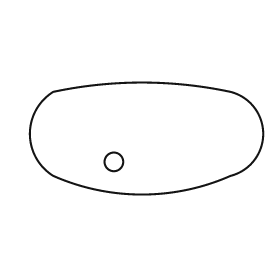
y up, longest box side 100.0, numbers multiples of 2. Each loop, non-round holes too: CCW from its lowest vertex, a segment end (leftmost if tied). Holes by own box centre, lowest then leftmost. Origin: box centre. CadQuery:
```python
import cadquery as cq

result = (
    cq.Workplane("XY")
    .moveTo(-40.0, -16.0)
    .threePointArc((-2.0, -24.0), (36.0, -16.0))
    .threePointArc((50.0, 2.0), (36.0, 20.0))
    .threePointArc((-2.0, 24.0), (-40.0, 20.0))
    .threePointArc((-50.0, 2.0), (-40.0, -16.0))
    .close()
    .moveTo(-14.0, -10.0)
    .circle(4.0)
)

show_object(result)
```